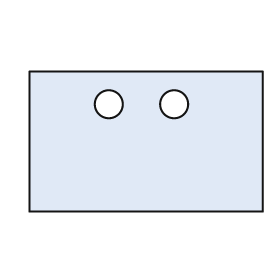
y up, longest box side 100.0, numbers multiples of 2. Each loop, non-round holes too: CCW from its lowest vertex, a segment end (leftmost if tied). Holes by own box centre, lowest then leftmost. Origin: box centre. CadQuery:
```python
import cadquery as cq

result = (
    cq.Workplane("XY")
    .moveTo(-50.0, -30.0)
    .lineTo(50.0, -30.0)
    .lineTo(50.0, 30.0)
    .lineTo(-50.0, 30.0)
    .close()
    .moveTo(-16.0, 16.0)
    .circle(6.0)
    .moveTo(12.0, 16.0)
    .circle(6.0)
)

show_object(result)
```